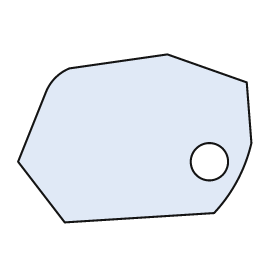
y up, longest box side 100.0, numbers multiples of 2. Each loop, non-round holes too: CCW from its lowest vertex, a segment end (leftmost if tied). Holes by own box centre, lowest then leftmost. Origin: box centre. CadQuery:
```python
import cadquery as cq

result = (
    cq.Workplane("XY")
    .moveTo(-30.0, -36.0)
    .lineTo(34.0, -32.0)
    .threePointArc((44.0, -18.0), (50.0, -2.0))
    .lineTo(48.0, 24.0)
    .lineTo(14.0, 36.0)
    .lineTo(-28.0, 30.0)
    .threePointArc((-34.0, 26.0), (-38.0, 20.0))
    .lineTo(-50.0, -10.0)
    .close()
    .moveTo(32.0, -10.0)
    .circle(8.0)
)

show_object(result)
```